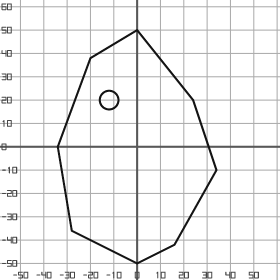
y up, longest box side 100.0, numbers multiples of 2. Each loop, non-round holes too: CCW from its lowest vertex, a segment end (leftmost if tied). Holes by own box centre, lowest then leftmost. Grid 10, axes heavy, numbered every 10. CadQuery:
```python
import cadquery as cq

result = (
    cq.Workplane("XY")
    .moveTo(0.0, -50.0)
    .lineTo(16.0, -42.0)
    .lineTo(34.0, -10.0)
    .lineTo(24.0, 20.0)
    .lineTo(0.0, 50.0)
    .lineTo(-20.0, 38.0)
    .lineTo(-34.0, 0.0)
    .lineTo(-28.0, -36.0)
    .close()
    .moveTo(-12.0, 20.0)
    .circle(4.0)
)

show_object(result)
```